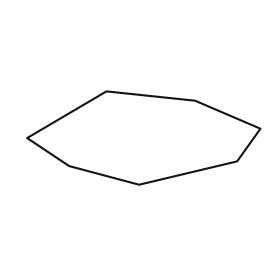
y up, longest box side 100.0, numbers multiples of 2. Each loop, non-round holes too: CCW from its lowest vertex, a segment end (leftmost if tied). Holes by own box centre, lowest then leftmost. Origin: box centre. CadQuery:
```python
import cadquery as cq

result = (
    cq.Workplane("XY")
    .moveTo(-2.0, -20.0)
    .lineTo(40.0, -10.0)
    .lineTo(50.0, 4.0)
    .lineTo(22.0, 16.0)
    .lineTo(-16.0, 20.0)
    .lineTo(-50.0, 0.0)
    .lineTo(-32.0, -12.0)
    .close()
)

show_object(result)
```